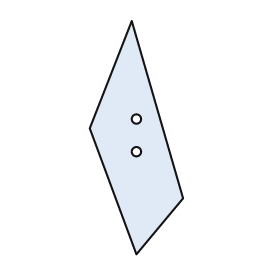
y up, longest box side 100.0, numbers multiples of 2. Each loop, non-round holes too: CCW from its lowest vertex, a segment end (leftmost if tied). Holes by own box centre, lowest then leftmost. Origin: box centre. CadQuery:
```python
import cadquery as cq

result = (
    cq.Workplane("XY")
    .moveTo(0.0, -50.0)
    .lineTo(20.0, -26.0)
    .lineTo(-2.0, 50.0)
    .lineTo(-20.0, 4.0)
    .close()
    .moveTo(0.0, -6.0)
    .circle(2.0)
    .moveTo(0.0, 8.0)
    .circle(2.0)
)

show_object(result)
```